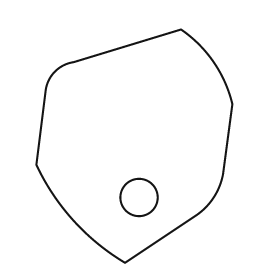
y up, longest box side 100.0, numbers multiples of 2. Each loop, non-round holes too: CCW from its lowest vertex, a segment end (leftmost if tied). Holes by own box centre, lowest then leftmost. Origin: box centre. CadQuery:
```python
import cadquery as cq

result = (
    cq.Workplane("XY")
    .moveTo(-4.0, -50.0)
    .lineTo(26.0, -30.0)
    .threePointArc((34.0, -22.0), (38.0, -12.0))
    .lineTo(42.0, 18.0)
    .threePointArc((34.0, 36.0), (20.0, 50.0))
    .lineTo(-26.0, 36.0)
    .threePointArc((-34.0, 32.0), (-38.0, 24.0))
    .lineTo(-42.0, -8.0)
    .threePointArc((-26.0, -32.0), (-4.0, -50.0))
    .close()
    .moveTo(2.0, -22.0)
    .circle(8.0)
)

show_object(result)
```